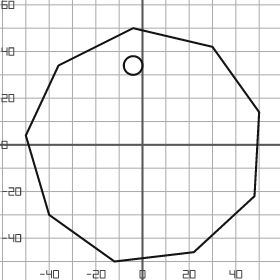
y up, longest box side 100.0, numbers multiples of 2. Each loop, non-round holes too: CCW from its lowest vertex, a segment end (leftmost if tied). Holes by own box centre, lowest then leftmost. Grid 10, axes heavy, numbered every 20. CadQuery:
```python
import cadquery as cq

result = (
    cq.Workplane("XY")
    .moveTo(-12.0, -50.0)
    .lineTo(22.0, -46.0)
    .lineTo(48.0, -22.0)
    .lineTo(50.0, 14.0)
    .lineTo(30.0, 42.0)
    .lineTo(-4.0, 50.0)
    .lineTo(-36.0, 34.0)
    .lineTo(-50.0, 4.0)
    .lineTo(-40.0, -30.0)
    .close()
    .moveTo(-4.0, 34.0)
    .circle(4.0)
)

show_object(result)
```